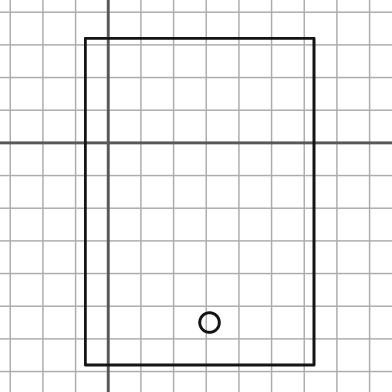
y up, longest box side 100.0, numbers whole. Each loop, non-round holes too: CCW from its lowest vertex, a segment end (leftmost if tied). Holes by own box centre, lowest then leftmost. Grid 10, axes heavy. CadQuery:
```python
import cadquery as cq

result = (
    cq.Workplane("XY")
    .moveTo(-7.0, -68.0)
    .lineTo(63.0, -68.0)
    .lineTo(63.0, 32.0)
    .lineTo(-7.0, 32.0)
    .close()
    .moveTo(31.0, -55.0)
    .circle(3.0)
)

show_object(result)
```